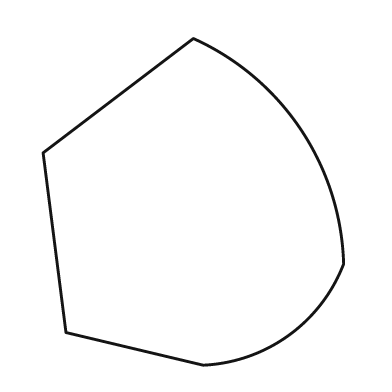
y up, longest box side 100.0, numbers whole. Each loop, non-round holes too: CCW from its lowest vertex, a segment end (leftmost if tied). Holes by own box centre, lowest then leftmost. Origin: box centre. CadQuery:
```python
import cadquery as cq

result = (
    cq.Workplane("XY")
    .moveTo(3.0, -50.0)
    .threePointArc((29.0, -41.0), (46.0, -19.0))
    .threePointArc((33.0, 22.0), (0.0, 50.0))
    .lineTo(-46.0, 15.0)
    .lineTo(-39.0, -40.0)
    .close()
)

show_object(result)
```